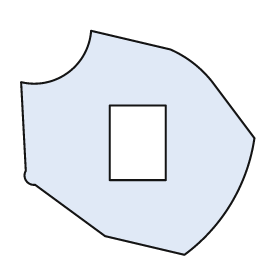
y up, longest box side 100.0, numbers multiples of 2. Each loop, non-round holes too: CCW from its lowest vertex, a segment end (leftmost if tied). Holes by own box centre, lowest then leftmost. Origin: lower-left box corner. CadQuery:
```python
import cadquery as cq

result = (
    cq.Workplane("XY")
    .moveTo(70.0, 0.0)
    .threePointArc((90.0, 22.0), (100.0, 50.0))
    .lineTo(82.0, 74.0)
    .threePointArc((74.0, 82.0), (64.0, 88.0))
    .lineTo(30.0, 96.0)
    .threePointArc((20.0, 78.0), (0.0, 74.0))
    .lineTo(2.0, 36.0)
    .threePointArc((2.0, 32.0), (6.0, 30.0))
    .lineTo(36.0, 8.0)
    .close()
    .moveTo(38.0, 32.0)
    .lineTo(62.0, 32.0)
    .lineTo(62.0, 64.0)
    .lineTo(38.0, 64.0)
    .close()
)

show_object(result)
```